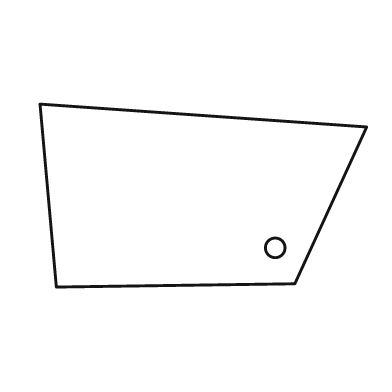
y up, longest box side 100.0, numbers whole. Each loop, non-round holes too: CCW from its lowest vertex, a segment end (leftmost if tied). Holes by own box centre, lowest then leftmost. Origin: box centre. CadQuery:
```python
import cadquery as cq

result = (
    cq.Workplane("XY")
    .moveTo(-45.0, -28.0)
    .lineTo(28.0, -27.0)
    .lineTo(50.0, 21.0)
    .lineTo(-50.0, 28.0)
    .close()
    .moveTo(22.0, -16.0)
    .circle(3.0)
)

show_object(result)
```